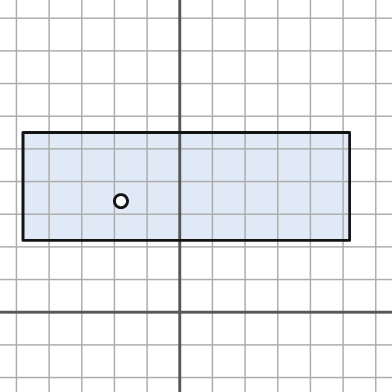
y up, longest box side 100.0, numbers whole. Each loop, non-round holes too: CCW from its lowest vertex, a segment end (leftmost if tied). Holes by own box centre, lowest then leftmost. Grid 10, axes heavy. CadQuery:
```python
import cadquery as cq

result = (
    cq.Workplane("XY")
    .moveTo(-48.0, 22.0)
    .lineTo(52.0, 22.0)
    .lineTo(52.0, 55.0)
    .lineTo(-48.0, 55.0)
    .close()
    .moveTo(-18.0, 34.0)
    .circle(2.0)
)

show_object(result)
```